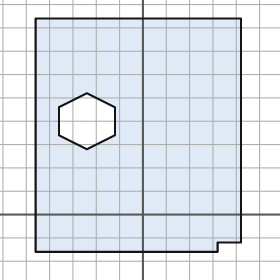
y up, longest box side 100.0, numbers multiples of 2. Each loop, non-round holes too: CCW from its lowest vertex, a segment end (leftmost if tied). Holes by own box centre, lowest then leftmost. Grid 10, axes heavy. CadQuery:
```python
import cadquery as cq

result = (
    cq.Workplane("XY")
    .moveTo(-46.0, -16.0)
    .lineTo(32.0, -16.0)
    .lineTo(32.0, -12.0)
    .lineTo(42.0, -12.0)
    .lineTo(42.0, 84.0)
    .lineTo(-46.0, 84.0)
    .close()
    .moveTo(-24.0, 28.0)
    .lineTo(-12.0, 34.0)
    .lineTo(-12.0, 46.0)
    .lineTo(-24.0, 52.0)
    .lineTo(-36.0, 46.0)
    .lineTo(-36.0, 34.0)
    .close()
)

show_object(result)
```